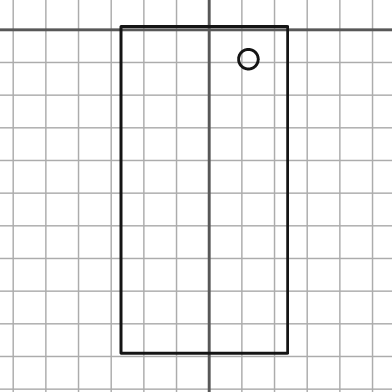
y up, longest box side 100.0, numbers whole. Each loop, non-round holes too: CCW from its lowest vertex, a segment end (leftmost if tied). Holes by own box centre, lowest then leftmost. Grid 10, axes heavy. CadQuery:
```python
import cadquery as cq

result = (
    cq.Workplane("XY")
    .moveTo(-27.0, -99.0)
    .lineTo(24.0, -99.0)
    .lineTo(24.0, 1.0)
    .lineTo(-27.0, 1.0)
    .close()
    .moveTo(12.0, -9.0)
    .circle(3.0)
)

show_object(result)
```